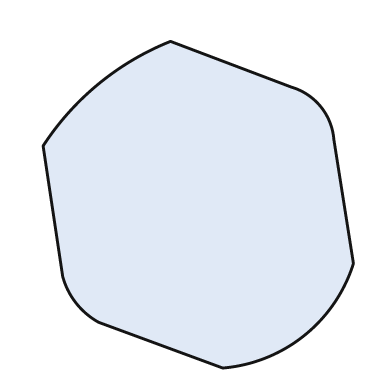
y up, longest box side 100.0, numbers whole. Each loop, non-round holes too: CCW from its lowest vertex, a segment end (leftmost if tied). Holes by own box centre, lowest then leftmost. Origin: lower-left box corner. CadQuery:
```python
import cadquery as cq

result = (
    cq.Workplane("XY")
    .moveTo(55.0, 0.0)
    .threePointArc((80.0, 10.0), (95.0, 32.0))
    .lineTo(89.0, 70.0)
    .threePointArc((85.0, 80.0), (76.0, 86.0))
    .lineTo(39.0, 100.0)
    .threePointArc((17.0, 87.0), (0.0, 68.0))
    .lineTo(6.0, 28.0)
    .threePointArc((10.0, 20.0), (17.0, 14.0))
    .close()
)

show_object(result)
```